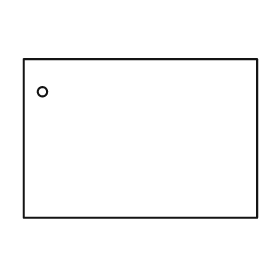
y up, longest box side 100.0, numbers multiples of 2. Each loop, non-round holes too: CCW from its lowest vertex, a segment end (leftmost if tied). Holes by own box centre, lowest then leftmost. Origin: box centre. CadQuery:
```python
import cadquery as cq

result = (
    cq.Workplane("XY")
    .moveTo(-50.0, -34.0)
    .lineTo(50.0, -34.0)
    .lineTo(50.0, 34.0)
    .lineTo(-50.0, 34.0)
    .close()
    .moveTo(-42.0, 20.0)
    .circle(2.0)
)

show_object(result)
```